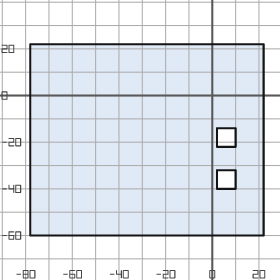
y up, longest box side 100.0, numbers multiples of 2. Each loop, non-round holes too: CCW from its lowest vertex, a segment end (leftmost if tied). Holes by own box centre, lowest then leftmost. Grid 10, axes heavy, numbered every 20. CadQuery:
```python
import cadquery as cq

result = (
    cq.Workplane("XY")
    .moveTo(-78.0, -60.0)
    .lineTo(22.0, -60.0)
    .lineTo(22.0, 22.0)
    .lineTo(-78.0, 22.0)
    .close()
    .moveTo(2.0, -40.0)
    .lineTo(10.0, -40.0)
    .lineTo(10.0, -32.0)
    .lineTo(2.0, -32.0)
    .close()
    .moveTo(2.0, -22.0)
    .lineTo(10.0, -22.0)
    .lineTo(10.0, -14.0)
    .lineTo(2.0, -14.0)
    .close()
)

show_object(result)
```